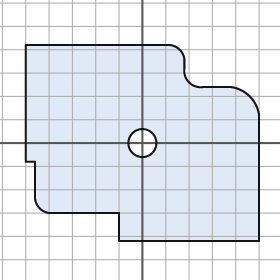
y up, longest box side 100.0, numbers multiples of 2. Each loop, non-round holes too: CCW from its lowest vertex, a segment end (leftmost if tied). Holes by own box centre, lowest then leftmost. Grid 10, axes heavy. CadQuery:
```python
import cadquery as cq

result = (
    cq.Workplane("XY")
    .moveTo(-10.0, -42.0)
    .lineTo(50.0, -42.0)
    .lineTo(50.0, 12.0)
    .threePointArc((46.0, 20.0), (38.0, 24.0))
    .lineTo(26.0, 24.0)
    .threePointArc((20.0, 26.0), (18.0, 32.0))
    .lineTo(18.0, 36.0)
    .threePointArc((16.0, 40.0), (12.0, 42.0))
    .lineTo(-50.0, 42.0)
    .lineTo(-50.0, -8.0)
    .lineTo(-46.0, -8.0)
    .lineTo(-46.0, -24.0)
    .threePointArc((-44.0, -28.0), (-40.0, -30.0))
    .lineTo(-10.0, -30.0)
    .close()
    .moveTo(0.0, 0.0)
    .circle(6.0)
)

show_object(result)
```